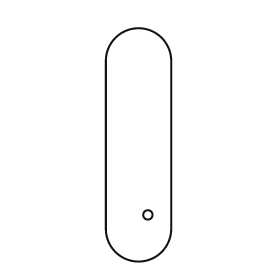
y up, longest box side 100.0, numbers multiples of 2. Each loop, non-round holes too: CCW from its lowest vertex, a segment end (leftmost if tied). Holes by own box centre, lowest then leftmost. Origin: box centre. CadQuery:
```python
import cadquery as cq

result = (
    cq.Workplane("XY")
    .moveTo(-14.0, -36.0)
    .threePointArc((0.0, -50.0), (14.0, -36.0))
    .lineTo(14.0, 36.0)
    .threePointArc((0.0, 50.0), (-14.0, 36.0))
    .close()
    .moveTo(4.0, -30.0)
    .circle(2.0)
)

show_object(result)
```